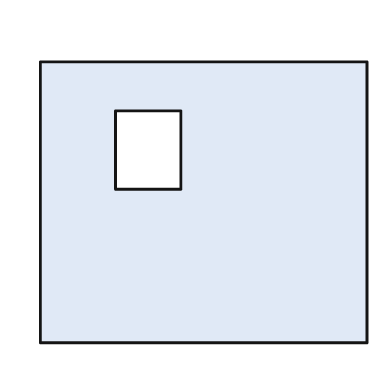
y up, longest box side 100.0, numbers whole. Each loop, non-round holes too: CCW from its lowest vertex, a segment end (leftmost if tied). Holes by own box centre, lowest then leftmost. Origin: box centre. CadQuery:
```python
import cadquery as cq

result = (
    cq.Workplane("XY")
    .moveTo(-50.0, -43.0)
    .lineTo(50.0, -43.0)
    .lineTo(50.0, 43.0)
    .lineTo(-50.0, 43.0)
    .close()
    .moveTo(-27.0, 4.0)
    .lineTo(-7.0, 4.0)
    .lineTo(-7.0, 28.0)
    .lineTo(-27.0, 28.0)
    .close()
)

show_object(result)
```